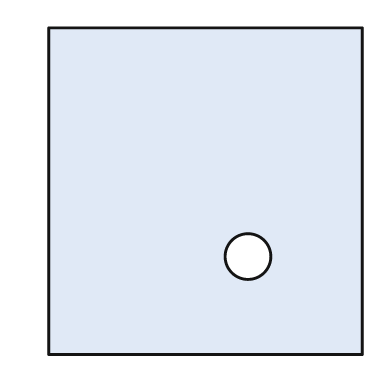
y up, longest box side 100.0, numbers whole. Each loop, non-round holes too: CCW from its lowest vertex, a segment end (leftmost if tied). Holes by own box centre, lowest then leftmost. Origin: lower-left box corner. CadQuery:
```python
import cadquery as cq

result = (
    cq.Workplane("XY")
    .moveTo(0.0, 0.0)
    .lineTo(96.0, 0.0)
    .lineTo(96.0, 100.0)
    .lineTo(0.0, 100.0)
    .close()
    .moveTo(61.0, 30.0)
    .circle(7.0)
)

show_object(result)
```